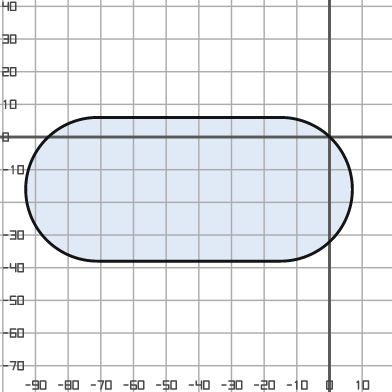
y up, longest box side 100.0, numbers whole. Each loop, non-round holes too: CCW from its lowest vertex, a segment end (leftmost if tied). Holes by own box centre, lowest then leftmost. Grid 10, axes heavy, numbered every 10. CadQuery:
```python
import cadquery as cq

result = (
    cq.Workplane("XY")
    .moveTo(-71.0, -38.0)
    .lineTo(-15.0, -38.0)
    .threePointArc((7.0, -16.0), (-15.0, 6.0))
    .lineTo(-71.0, 6.0)
    .threePointArc((-93.0, -16.0), (-71.0, -38.0))
    .close()
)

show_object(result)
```